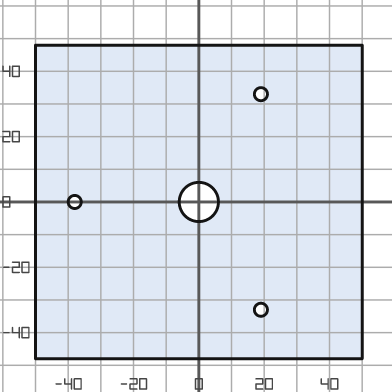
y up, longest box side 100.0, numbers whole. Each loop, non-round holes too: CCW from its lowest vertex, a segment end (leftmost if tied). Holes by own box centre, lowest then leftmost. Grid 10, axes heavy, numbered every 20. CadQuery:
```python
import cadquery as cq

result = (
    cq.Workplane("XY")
    .moveTo(-50.0, -48.0)
    .lineTo(50.0, -48.0)
    .lineTo(50.0, 48.0)
    .lineTo(-50.0, 48.0)
    .close()
    .moveTo(19.0, -33.0)
    .circle(2.0)
    .moveTo(-38.0, 0.0)
    .circle(2.0)
    .moveTo(0.0, 0.0)
    .circle(6.0)
    .moveTo(19.0, 33.0)
    .circle(2.0)
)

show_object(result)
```